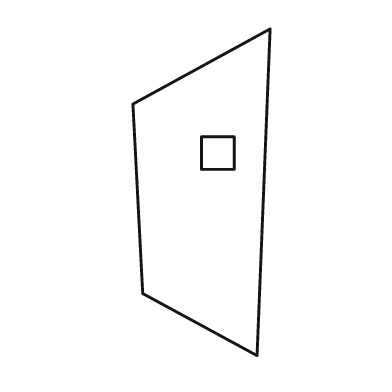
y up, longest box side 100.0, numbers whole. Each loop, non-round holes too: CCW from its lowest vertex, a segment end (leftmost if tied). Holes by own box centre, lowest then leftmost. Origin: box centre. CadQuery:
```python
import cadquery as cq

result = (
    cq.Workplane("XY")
    .moveTo(17.0, -50.0)
    .lineTo(21.0, 50.0)
    .lineTo(-21.0, 27.0)
    .lineTo(-18.0, -31.0)
    .close()
    .moveTo(0.0, 7.0)
    .lineTo(10.0, 7.0)
    .lineTo(10.0, 17.0)
    .lineTo(0.0, 17.0)
    .close()
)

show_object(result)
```